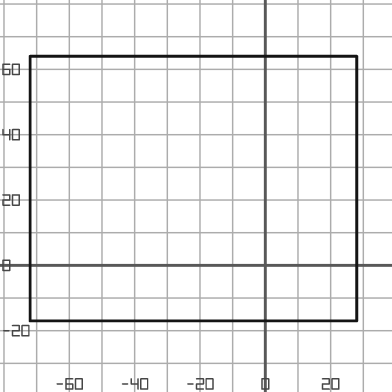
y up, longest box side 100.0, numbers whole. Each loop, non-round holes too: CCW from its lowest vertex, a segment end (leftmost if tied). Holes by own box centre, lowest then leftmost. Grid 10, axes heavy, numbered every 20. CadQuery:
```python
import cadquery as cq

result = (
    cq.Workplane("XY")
    .moveTo(-72.0, -17.0)
    .lineTo(28.0, -17.0)
    .lineTo(28.0, 64.0)
    .lineTo(-72.0, 64.0)
    .close()
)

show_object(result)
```